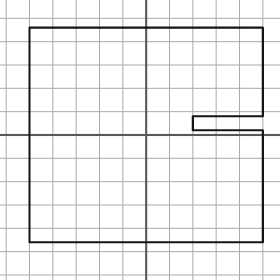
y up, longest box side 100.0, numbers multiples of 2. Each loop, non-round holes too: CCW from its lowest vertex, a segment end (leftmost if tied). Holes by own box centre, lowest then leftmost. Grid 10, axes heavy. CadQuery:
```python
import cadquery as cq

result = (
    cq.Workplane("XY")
    .moveTo(-50.0, -46.0)
    .lineTo(50.0, -46.0)
    .lineTo(50.0, 2.0)
    .lineTo(20.0, 2.0)
    .lineTo(20.0, 8.0)
    .lineTo(50.0, 8.0)
    .lineTo(50.0, 46.0)
    .lineTo(-50.0, 46.0)
    .close()
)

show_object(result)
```